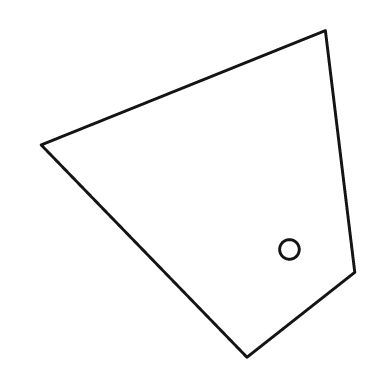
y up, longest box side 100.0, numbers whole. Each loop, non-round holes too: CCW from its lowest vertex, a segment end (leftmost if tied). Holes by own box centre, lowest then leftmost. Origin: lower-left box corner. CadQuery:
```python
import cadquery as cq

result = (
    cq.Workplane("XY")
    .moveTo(63.0, 0.0)
    .lineTo(96.0, 26.0)
    .lineTo(87.0, 100.0)
    .lineTo(0.0, 65.0)
    .close()
    .moveTo(76.0, 33.0)
    .circle(3.0)
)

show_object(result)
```